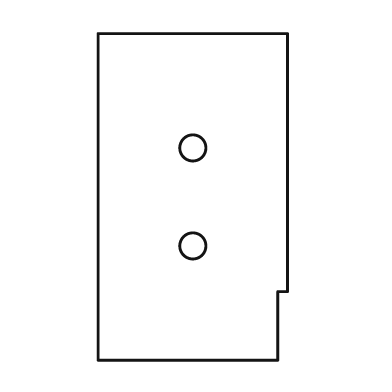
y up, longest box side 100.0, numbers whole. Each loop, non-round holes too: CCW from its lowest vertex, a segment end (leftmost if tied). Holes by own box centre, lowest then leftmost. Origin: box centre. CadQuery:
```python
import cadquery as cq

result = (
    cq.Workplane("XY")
    .moveTo(-29.0, -50.0)
    .lineTo(26.0, -50.0)
    .lineTo(26.0, -29.0)
    .lineTo(29.0, -29.0)
    .lineTo(29.0, 50.0)
    .lineTo(-29.0, 50.0)
    .close()
    .moveTo(0.0, -15.0)
    .circle(4.0)
    .moveTo(0.0, 15.0)
    .circle(4.0)
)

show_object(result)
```